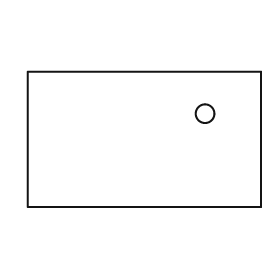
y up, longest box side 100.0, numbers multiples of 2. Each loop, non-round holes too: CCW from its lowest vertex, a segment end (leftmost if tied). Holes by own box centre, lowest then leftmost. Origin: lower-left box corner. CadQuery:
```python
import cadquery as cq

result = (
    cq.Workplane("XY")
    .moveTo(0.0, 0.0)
    .lineTo(100.0, 0.0)
    .lineTo(100.0, 58.0)
    .lineTo(0.0, 58.0)
    .close()
    .moveTo(76.0, 40.0)
    .circle(4.0)
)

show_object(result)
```